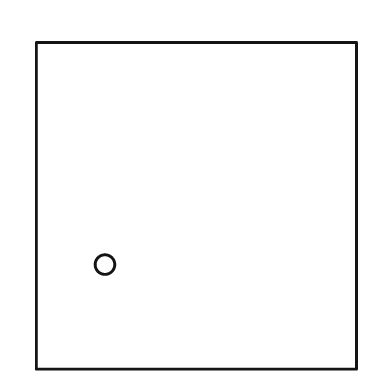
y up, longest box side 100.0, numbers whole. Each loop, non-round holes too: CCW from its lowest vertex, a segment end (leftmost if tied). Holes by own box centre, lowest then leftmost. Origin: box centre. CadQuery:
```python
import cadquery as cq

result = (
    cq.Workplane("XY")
    .moveTo(-49.0, -50.0)
    .lineTo(49.0, -50.0)
    .lineTo(49.0, 50.0)
    .lineTo(-49.0, 50.0)
    .close()
    .moveTo(-28.0, -18.0)
    .circle(3.0)
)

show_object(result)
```